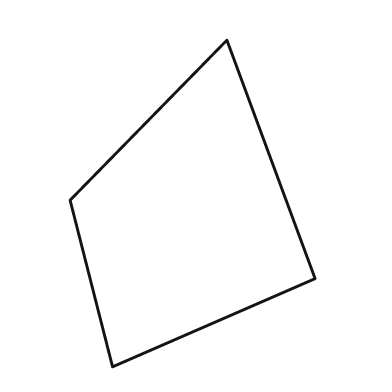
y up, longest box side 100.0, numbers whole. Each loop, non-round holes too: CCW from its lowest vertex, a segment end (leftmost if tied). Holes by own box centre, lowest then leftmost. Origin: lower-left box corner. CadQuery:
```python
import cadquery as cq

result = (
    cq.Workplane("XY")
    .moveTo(13.0, 0.0)
    .lineTo(75.0, 27.0)
    .lineTo(48.0, 100.0)
    .lineTo(0.0, 51.0)
    .close()
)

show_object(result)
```